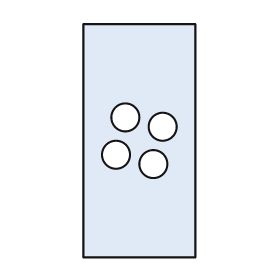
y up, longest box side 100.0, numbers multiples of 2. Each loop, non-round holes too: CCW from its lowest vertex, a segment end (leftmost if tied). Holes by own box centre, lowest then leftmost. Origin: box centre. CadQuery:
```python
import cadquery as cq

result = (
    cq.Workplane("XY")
    .moveTo(-24.0, -50.0)
    .lineTo(24.0, -50.0)
    .lineTo(24.0, 50.0)
    .lineTo(-24.0, 50.0)
    .close()
    .moveTo(6.0, -10.0)
    .circle(6.0)
    .moveTo(-10.0, -6.0)
    .circle(6.0)
    .moveTo(10.0, 6.0)
    .circle(6.0)
    .moveTo(-6.0, 10.0)
    .circle(6.0)
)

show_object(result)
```